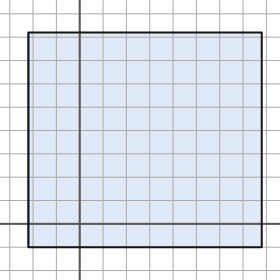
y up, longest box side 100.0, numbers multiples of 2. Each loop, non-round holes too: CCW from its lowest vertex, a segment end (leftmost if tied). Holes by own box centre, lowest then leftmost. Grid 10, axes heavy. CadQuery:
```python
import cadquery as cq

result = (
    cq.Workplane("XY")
    .moveTo(-22.0, -10.0)
    .lineTo(78.0, -10.0)
    .lineTo(78.0, 82.0)
    .lineTo(-22.0, 82.0)
    .close()
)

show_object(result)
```